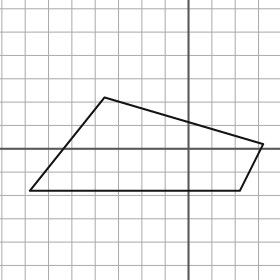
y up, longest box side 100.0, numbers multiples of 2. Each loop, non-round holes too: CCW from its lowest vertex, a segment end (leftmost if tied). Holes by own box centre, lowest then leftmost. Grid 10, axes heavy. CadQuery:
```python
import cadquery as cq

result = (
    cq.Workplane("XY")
    .moveTo(-68.0, -18.0)
    .lineTo(22.0, -18.0)
    .lineTo(32.0, 2.0)
    .lineTo(-36.0, 22.0)
    .close()
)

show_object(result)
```